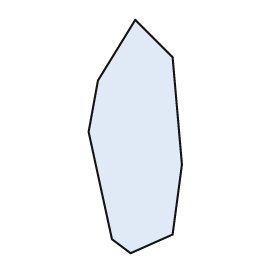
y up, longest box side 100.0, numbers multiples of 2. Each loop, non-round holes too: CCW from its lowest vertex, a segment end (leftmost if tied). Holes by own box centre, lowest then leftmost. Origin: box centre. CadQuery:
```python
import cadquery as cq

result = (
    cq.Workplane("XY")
    .moveTo(-2.0, -50.0)
    .lineTo(16.0, -42.0)
    .lineTo(20.0, -12.0)
    .lineTo(16.0, 34.0)
    .lineTo(0.0, 50.0)
    .lineTo(-16.0, 24.0)
    .lineTo(-20.0, 2.0)
    .lineTo(-10.0, -44.0)
    .close()
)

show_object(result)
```